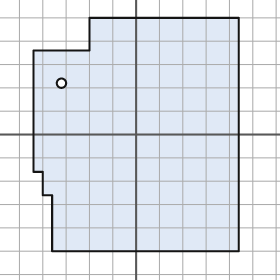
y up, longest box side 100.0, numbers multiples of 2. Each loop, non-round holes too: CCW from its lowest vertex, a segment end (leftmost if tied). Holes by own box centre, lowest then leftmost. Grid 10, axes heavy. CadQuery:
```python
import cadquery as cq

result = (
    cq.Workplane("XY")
    .moveTo(-36.0, -50.0)
    .lineTo(44.0, -50.0)
    .lineTo(44.0, 50.0)
    .lineTo(-20.0, 50.0)
    .lineTo(-20.0, 36.0)
    .lineTo(-44.0, 36.0)
    .lineTo(-44.0, -16.0)
    .lineTo(-40.0, -16.0)
    .lineTo(-40.0, -26.0)
    .lineTo(-36.0, -26.0)
    .close()
    .moveTo(-32.0, 22.0)
    .circle(2.0)
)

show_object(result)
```